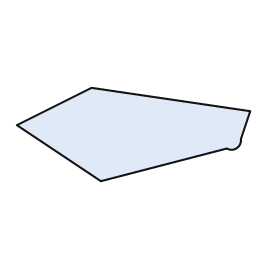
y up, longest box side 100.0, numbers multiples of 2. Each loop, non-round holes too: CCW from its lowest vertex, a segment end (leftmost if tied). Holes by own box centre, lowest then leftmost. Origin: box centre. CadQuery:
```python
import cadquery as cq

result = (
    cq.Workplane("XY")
    .moveTo(-14.0, -20.0)
    .lineTo(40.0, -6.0)
    .threePointArc((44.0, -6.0), (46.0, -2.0))
    .lineTo(50.0, 10.0)
    .lineTo(-18.0, 20.0)
    .lineTo(-50.0, 4.0)
    .close()
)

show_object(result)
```